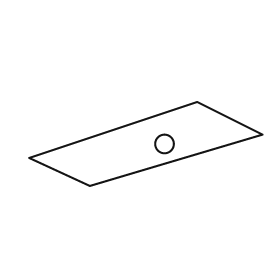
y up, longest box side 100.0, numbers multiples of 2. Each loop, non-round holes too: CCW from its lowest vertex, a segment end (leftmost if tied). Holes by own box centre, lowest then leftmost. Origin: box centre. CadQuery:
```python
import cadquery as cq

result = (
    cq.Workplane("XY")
    .moveTo(-24.0, -18.0)
    .lineTo(50.0, 4.0)
    .lineTo(22.0, 18.0)
    .lineTo(-50.0, -6.0)
    .close()
    .moveTo(8.0, 0.0)
    .circle(4.0)
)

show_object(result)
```